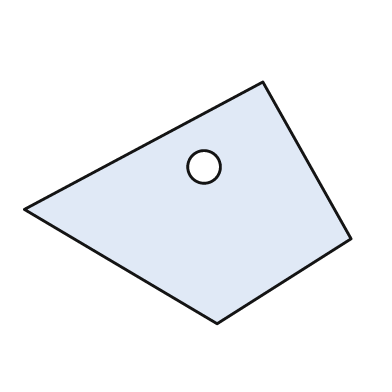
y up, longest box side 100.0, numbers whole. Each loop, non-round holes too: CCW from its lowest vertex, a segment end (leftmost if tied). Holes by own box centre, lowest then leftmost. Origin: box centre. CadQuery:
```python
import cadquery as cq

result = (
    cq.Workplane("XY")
    .moveTo(9.0, -37.0)
    .lineTo(50.0, -11.0)
    .lineTo(23.0, 37.0)
    .lineTo(-50.0, -2.0)
    .close()
    .moveTo(5.0, 11.0)
    .circle(5.0)
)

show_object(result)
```